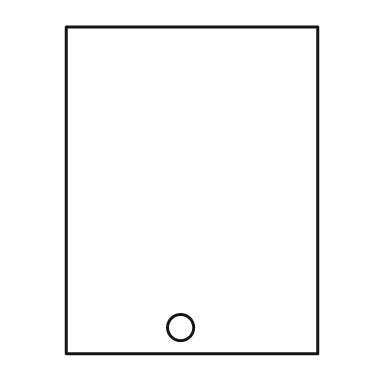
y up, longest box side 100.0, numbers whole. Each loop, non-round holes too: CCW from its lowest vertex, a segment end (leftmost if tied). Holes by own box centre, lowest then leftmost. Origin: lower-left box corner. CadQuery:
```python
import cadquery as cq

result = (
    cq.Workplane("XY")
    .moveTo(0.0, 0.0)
    .lineTo(77.0, 0.0)
    .lineTo(77.0, 100.0)
    .lineTo(0.0, 100.0)
    .close()
    .moveTo(35.0, 8.0)
    .circle(4.0)
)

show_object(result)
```